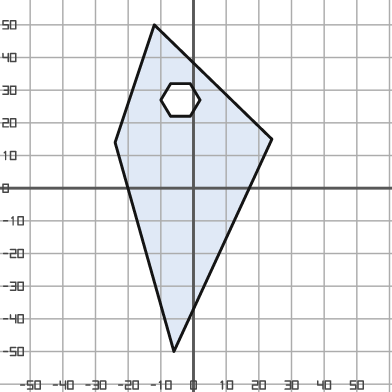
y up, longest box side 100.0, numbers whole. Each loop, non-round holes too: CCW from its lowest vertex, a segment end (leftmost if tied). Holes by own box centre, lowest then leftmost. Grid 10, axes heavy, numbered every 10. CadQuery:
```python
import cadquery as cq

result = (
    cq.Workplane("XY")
    .moveTo(-6.0, -50.0)
    .lineTo(24.0, 15.0)
    .lineTo(-12.0, 50.0)
    .lineTo(-24.0, 14.0)
    .close()
    .moveTo(-7.0, 22.0)
    .lineTo(-1.0, 22.0)
    .lineTo(2.0, 27.0)
    .lineTo(-1.0, 32.0)
    .lineTo(-7.0, 32.0)
    .lineTo(-10.0, 27.0)
    .close()
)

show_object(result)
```